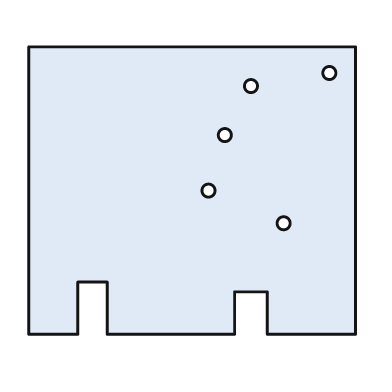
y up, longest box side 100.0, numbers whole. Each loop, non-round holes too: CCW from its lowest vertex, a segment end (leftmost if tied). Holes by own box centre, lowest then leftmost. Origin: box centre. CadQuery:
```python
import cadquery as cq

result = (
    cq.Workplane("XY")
    .moveTo(-50.0, -44.0)
    .lineTo(-35.0, -44.0)
    .lineTo(-35.0, -28.0)
    .lineTo(-26.0, -28.0)
    .lineTo(-26.0, -44.0)
    .lineTo(13.0, -44.0)
    .lineTo(13.0, -31.0)
    .lineTo(23.0, -31.0)
    .lineTo(23.0, -44.0)
    .lineTo(50.0, -44.0)
    .lineTo(50.0, 44.0)
    .lineTo(-50.0, 44.0)
    .close()
    .moveTo(28.0, -10.0)
    .circle(2.0)
    .moveTo(5.0, 0.0)
    .circle(2.0)
    .moveTo(10.0, 17.0)
    .circle(2.0)
    .moveTo(18.0, 32.0)
    .circle(2.0)
    .moveTo(42.0, 36.0)
    .circle(2.0)
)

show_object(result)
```